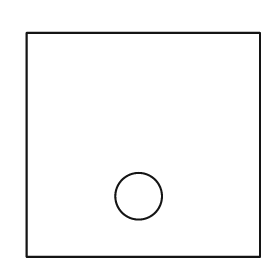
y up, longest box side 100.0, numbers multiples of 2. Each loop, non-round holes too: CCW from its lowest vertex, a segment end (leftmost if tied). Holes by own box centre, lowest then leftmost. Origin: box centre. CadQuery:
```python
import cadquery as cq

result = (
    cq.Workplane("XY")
    .moveTo(-50.0, -48.0)
    .lineTo(50.0, -48.0)
    .lineTo(50.0, 48.0)
    .lineTo(-50.0, 48.0)
    .close()
    .moveTo(-2.0, -22.0)
    .circle(10.0)
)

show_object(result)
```